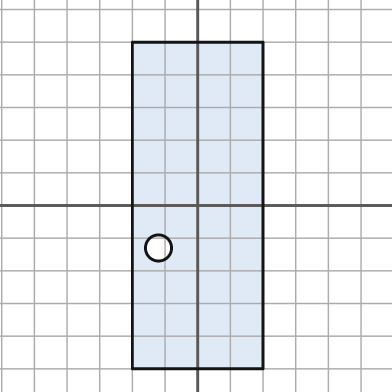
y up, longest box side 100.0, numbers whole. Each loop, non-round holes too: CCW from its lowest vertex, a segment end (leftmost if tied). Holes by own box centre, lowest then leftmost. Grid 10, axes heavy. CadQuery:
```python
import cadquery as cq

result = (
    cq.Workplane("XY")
    .moveTo(-20.0, -50.0)
    .lineTo(20.0, -50.0)
    .lineTo(20.0, 50.0)
    .lineTo(-20.0, 50.0)
    .close()
    .moveTo(-12.0, -13.0)
    .circle(4.0)
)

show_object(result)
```